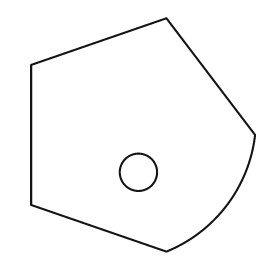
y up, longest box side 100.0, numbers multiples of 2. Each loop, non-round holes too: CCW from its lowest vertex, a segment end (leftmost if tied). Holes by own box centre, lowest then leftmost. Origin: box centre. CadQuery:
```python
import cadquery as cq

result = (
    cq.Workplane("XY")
    .moveTo(10.0, -50.0)
    .threePointArc((36.0, -30.0), (48.0, 0.0))
    .lineTo(10.0, 50.0)
    .lineTo(-48.0, 30.0)
    .lineTo(-48.0, -30.0)
    .close()
    .moveTo(-2.0, -16.0)
    .circle(8.0)
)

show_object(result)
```